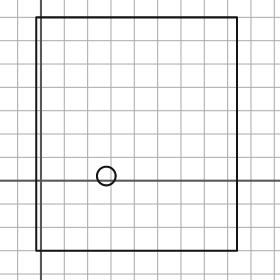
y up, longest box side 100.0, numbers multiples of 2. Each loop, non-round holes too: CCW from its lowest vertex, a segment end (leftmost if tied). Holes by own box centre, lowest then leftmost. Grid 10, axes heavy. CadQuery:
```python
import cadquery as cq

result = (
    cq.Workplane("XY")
    .moveTo(-2.0, -30.0)
    .lineTo(84.0, -30.0)
    .lineTo(84.0, 70.0)
    .lineTo(-2.0, 70.0)
    .close()
    .moveTo(28.0, 2.0)
    .circle(4.0)
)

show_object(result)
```